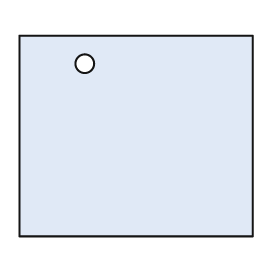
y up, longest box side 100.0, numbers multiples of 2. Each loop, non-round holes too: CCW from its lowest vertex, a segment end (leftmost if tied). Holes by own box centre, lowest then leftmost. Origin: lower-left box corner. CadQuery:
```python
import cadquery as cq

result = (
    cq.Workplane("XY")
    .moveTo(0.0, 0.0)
    .lineTo(100.0, 0.0)
    .lineTo(100.0, 86.0)
    .lineTo(0.0, 86.0)
    .close()
    .moveTo(28.0, 74.0)
    .circle(4.0)
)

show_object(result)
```